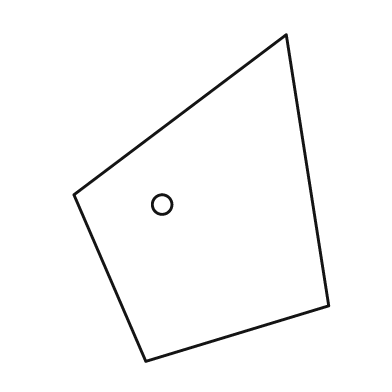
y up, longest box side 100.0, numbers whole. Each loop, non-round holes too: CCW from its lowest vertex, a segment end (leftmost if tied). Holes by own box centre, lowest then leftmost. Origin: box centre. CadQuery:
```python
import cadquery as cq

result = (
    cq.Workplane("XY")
    .moveTo(-17.0, -50.0)
    .lineTo(39.0, -33.0)
    .lineTo(26.0, 50.0)
    .lineTo(-39.0, 1.0)
    .close()
    .moveTo(-12.0, -2.0)
    .circle(3.0)
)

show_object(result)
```